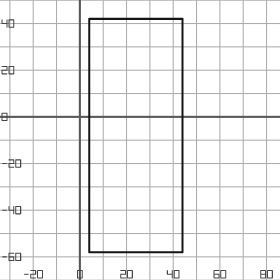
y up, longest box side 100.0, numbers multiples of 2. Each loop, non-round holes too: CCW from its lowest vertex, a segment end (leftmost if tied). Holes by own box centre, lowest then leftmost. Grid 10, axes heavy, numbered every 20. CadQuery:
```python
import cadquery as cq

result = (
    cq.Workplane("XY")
    .moveTo(4.0, -58.0)
    .lineTo(44.0, -58.0)
    .lineTo(44.0, 42.0)
    .lineTo(4.0, 42.0)
    .close()
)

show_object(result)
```